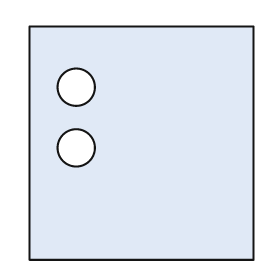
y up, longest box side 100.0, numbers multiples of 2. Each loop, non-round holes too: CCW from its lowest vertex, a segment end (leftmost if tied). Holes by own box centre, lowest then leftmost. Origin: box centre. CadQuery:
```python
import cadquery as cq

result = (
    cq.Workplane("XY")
    .moveTo(-48.0, -50.0)
    .lineTo(48.0, -50.0)
    .lineTo(48.0, 50.0)
    .lineTo(-48.0, 50.0)
    .close()
    .moveTo(-28.0, -2.0)
    .circle(8.0)
    .moveTo(-28.0, 24.0)
    .circle(8.0)
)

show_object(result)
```